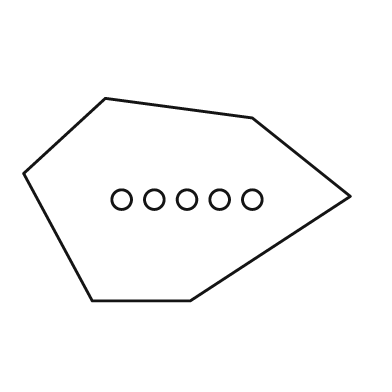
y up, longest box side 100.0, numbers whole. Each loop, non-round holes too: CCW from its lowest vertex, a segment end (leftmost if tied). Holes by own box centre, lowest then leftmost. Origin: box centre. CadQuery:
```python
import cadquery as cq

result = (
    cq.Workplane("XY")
    .moveTo(-29.0, -31.0)
    .lineTo(1.0, -31.0)
    .lineTo(50.0, 1.0)
    .lineTo(20.0, 25.0)
    .lineTo(-25.0, 31.0)
    .lineTo(-50.0, 8.0)
    .close()
    .moveTo(-20.0, 0.0)
    .circle(3.0)
    .moveTo(-10.0, 0.0)
    .circle(3.0)
    .moveTo(0.0, 0.0)
    .circle(3.0)
    .moveTo(10.0, 0.0)
    .circle(3.0)
    .moveTo(20.0, 0.0)
    .circle(3.0)
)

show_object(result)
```